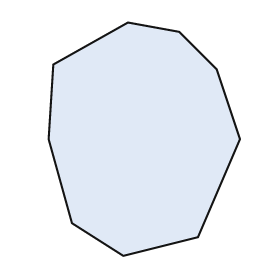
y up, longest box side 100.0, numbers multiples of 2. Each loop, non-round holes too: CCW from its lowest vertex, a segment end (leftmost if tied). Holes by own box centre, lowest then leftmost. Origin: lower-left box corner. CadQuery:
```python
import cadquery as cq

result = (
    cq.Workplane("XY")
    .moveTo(32.0, 0.0)
    .lineTo(64.0, 8.0)
    .lineTo(82.0, 50.0)
    .lineTo(72.0, 80.0)
    .lineTo(56.0, 96.0)
    .lineTo(34.0, 100.0)
    .lineTo(2.0, 82.0)
    .lineTo(0.0, 50.0)
    .lineTo(10.0, 14.0)
    .close()
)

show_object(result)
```